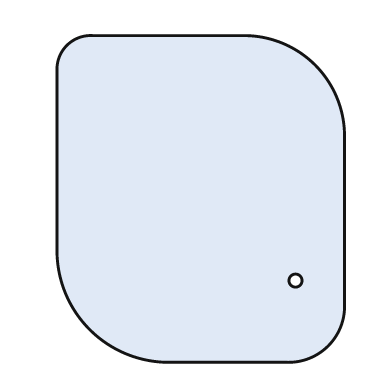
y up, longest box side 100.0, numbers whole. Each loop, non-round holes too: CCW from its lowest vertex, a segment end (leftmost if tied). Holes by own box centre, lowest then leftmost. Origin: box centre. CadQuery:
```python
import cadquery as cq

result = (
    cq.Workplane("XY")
    .moveTo(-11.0, -50.0)
    .lineTo(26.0, -50.0)
    .threePointArc((39.0, -45.0), (44.0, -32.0))
    .lineTo(44.0, 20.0)
    .threePointArc((35.0, 41.0), (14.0, 50.0))
    .lineTo(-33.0, 50.0)
    .threePointArc((-41.0, 47.0), (-44.0, 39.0))
    .lineTo(-44.0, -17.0)
    .threePointArc((-34.0, -40.0), (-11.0, -50.0))
    .close()
    .moveTo(29.0, -25.0)
    .circle(2.0)
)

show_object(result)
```